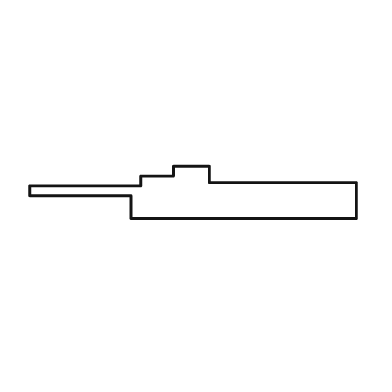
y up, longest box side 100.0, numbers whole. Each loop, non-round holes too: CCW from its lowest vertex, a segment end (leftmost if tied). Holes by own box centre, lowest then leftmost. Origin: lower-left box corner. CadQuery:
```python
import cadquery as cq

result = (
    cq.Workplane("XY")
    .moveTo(31.0, 0.0)
    .lineTo(100.0, 0.0)
    .lineTo(100.0, 11.0)
    .lineTo(55.0, 11.0)
    .lineTo(55.0, 16.0)
    .lineTo(44.0, 16.0)
    .lineTo(44.0, 13.0)
    .lineTo(34.0, 13.0)
    .lineTo(34.0, 10.0)
    .lineTo(0.0, 10.0)
    .lineTo(0.0, 7.0)
    .lineTo(31.0, 7.0)
    .close()
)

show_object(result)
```